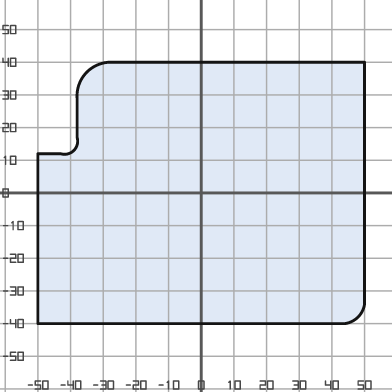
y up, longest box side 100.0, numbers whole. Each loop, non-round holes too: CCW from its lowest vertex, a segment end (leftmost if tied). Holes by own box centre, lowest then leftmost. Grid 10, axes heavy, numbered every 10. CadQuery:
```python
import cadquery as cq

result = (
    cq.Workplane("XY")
    .moveTo(-50.0, -40.0)
    .lineTo(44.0, -40.0)
    .threePointArc((48.0, -38.0), (50.0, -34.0))
    .lineTo(50.0, 40.0)
    .lineTo(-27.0, 40.0)
    .threePointArc((-35.0, 37.0), (-38.0, 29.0))
    .lineTo(-38.0, 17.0)
    .threePointArc((-39.0, 13.0), (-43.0, 12.0))
    .lineTo(-50.0, 12.0)
    .close()
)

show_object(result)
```